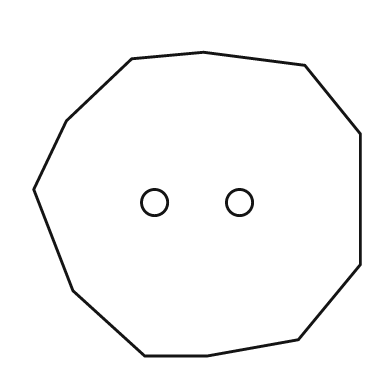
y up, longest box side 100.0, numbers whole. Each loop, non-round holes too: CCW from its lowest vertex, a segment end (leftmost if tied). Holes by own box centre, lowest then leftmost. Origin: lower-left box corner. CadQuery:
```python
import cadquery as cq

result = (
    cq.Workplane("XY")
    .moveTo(34.0, 0.0)
    .lineTo(53.0, 0.0)
    .lineTo(81.0, 5.0)
    .lineTo(100.0, 28.0)
    .lineTo(100.0, 68.0)
    .lineTo(83.0, 89.0)
    .lineTo(52.0, 93.0)
    .lineTo(30.0, 91.0)
    .lineTo(10.0, 72.0)
    .lineTo(0.0, 51.0)
    .lineTo(12.0, 20.0)
    .close()
    .moveTo(37.0, 47.0)
    .circle(4.0)
    .moveTo(63.0, 47.0)
    .circle(4.0)
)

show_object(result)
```